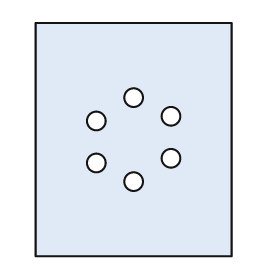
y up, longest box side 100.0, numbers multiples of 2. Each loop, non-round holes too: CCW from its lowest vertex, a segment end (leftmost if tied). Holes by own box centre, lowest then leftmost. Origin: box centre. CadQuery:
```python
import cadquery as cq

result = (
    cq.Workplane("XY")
    .moveTo(-42.0, -50.0)
    .lineTo(42.0, -50.0)
    .lineTo(42.0, 50.0)
    .lineTo(-42.0, 50.0)
    .close()
    .moveTo(0.0, -18.0)
    .circle(4.0)
    .moveTo(-16.0, -10.0)
    .circle(4.0)
    .moveTo(16.0, -8.0)
    .circle(4.0)
    .moveTo(-16.0, 8.0)
    .circle(4.0)
    .moveTo(16.0, 10.0)
    .circle(4.0)
    .moveTo(0.0, 18.0)
    .circle(4.0)
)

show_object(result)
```